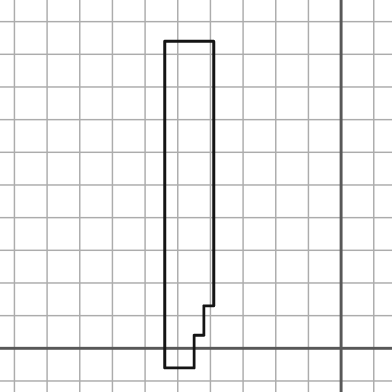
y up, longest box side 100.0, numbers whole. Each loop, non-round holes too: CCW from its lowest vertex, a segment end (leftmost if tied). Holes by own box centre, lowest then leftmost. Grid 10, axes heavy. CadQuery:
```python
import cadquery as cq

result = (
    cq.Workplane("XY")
    .moveTo(-54.0, -6.0)
    .lineTo(-45.0, -6.0)
    .lineTo(-45.0, 4.0)
    .lineTo(-42.0, 4.0)
    .lineTo(-42.0, 13.0)
    .lineTo(-39.0, 13.0)
    .lineTo(-39.0, 94.0)
    .lineTo(-54.0, 94.0)
    .close()
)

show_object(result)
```